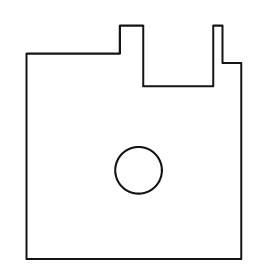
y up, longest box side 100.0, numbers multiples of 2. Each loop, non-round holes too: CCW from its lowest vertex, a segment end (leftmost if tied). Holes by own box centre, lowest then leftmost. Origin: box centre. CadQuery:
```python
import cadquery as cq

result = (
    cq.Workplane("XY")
    .moveTo(-46.0, -50.0)
    .lineTo(46.0, -50.0)
    .lineTo(46.0, 34.0)
    .lineTo(38.0, 34.0)
    .lineTo(38.0, 50.0)
    .lineTo(34.0, 50.0)
    .lineTo(34.0, 24.0)
    .lineTo(4.0, 24.0)
    .lineTo(4.0, 50.0)
    .lineTo(-6.0, 50.0)
    .lineTo(-6.0, 38.0)
    .lineTo(-46.0, 38.0)
    .close()
    .moveTo(2.0, -12.0)
    .circle(10.0)
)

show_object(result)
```